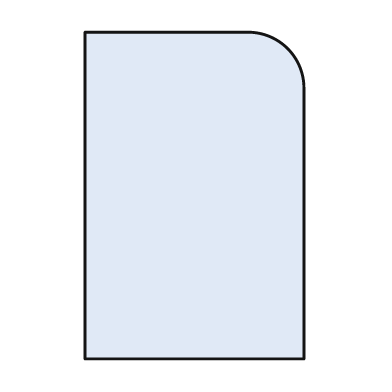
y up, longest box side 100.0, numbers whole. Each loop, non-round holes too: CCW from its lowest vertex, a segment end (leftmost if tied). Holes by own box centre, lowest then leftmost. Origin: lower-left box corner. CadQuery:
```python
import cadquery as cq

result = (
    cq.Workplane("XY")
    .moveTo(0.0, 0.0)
    .lineTo(67.0, 0.0)
    .lineTo(67.0, 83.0)
    .threePointArc((62.0, 95.0), (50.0, 100.0))
    .lineTo(0.0, 100.0)
    .close()
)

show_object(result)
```